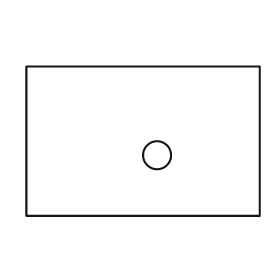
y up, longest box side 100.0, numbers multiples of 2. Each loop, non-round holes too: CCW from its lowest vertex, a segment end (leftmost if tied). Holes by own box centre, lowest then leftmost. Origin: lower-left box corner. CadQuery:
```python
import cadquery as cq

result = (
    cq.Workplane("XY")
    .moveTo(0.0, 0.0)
    .lineTo(100.0, 0.0)
    .lineTo(100.0, 64.0)
    .lineTo(0.0, 64.0)
    .close()
    .moveTo(56.0, 26.0)
    .circle(6.0)
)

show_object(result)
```